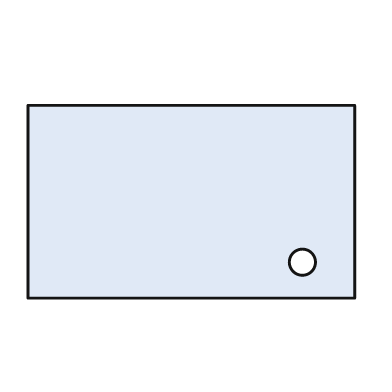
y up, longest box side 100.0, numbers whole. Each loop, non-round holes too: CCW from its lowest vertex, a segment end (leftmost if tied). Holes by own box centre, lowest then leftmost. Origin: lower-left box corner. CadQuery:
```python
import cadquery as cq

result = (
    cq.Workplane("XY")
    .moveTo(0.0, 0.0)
    .lineTo(100.0, 0.0)
    .lineTo(100.0, 59.0)
    .lineTo(0.0, 59.0)
    .close()
    .moveTo(84.0, 11.0)
    .circle(4.0)
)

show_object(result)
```